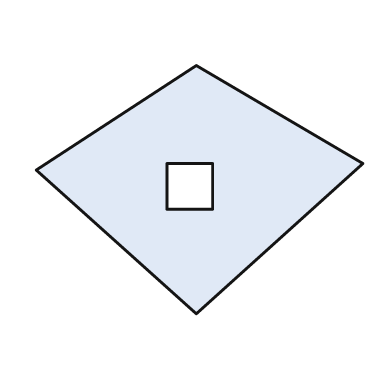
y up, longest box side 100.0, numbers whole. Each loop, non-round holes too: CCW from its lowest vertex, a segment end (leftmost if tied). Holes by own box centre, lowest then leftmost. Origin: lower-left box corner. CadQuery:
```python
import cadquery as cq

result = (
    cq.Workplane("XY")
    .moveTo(49.0, 0.0)
    .lineTo(100.0, 46.0)
    .lineTo(49.0, 76.0)
    .lineTo(0.0, 44.0)
    .close()
    .moveTo(40.0, 32.0)
    .lineTo(54.0, 32.0)
    .lineTo(54.0, 46.0)
    .lineTo(40.0, 46.0)
    .close()
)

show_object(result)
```